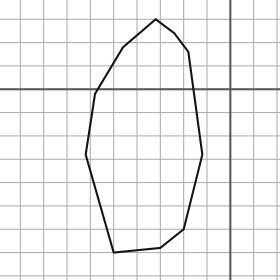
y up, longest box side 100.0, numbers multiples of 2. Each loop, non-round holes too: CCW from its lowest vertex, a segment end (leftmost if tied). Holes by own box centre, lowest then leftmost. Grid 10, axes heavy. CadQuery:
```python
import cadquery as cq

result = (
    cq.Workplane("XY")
    .moveTo(-50.0, -70.0)
    .lineTo(-30.0, -68.0)
    .lineTo(-20.0, -60.0)
    .lineTo(-12.0, -28.0)
    .lineTo(-18.0, 16.0)
    .lineTo(-24.0, 24.0)
    .lineTo(-32.0, 30.0)
    .lineTo(-46.0, 18.0)
    .lineTo(-58.0, -2.0)
    .lineTo(-62.0, -28.0)
    .close()
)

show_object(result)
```